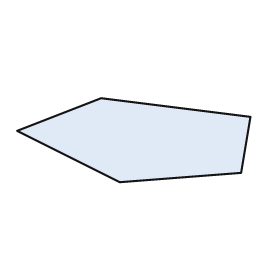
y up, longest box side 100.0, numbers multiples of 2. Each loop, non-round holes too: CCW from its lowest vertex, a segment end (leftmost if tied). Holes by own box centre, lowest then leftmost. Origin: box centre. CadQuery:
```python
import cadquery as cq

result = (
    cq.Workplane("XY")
    .moveTo(-6.0, -18.0)
    .lineTo(46.0, -14.0)
    .lineTo(50.0, 10.0)
    .lineTo(-14.0, 18.0)
    .lineTo(-50.0, 4.0)
    .close()
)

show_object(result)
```